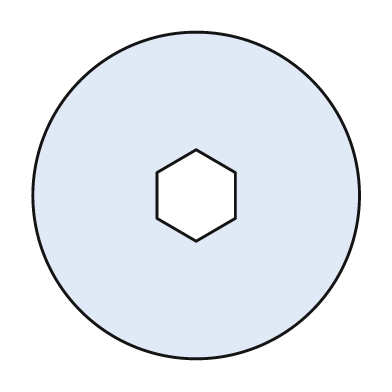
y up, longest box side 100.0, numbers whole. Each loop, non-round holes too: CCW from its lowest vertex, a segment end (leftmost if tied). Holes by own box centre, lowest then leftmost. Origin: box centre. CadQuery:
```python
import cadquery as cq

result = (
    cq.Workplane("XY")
    .moveTo(0.0, 0.0)
    .circle(50.0)
    .moveTo(0.0, -14.0)
    .lineTo(12.0, -7.0)
    .lineTo(12.0, 7.0)
    .lineTo(0.0, 14.0)
    .lineTo(-12.0, 7.0)
    .lineTo(-12.0, -7.0)
    .close()
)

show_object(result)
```